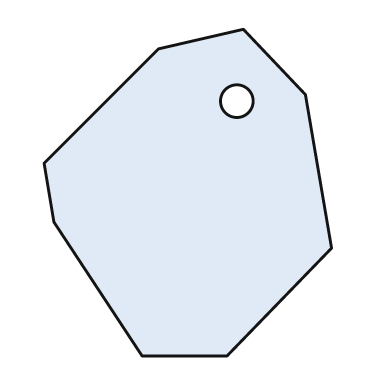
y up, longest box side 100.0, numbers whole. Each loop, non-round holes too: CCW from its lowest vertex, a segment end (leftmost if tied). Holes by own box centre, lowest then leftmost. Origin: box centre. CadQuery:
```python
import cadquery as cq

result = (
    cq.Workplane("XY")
    .moveTo(-14.0, -50.0)
    .lineTo(12.0, -50.0)
    .lineTo(44.0, -17.0)
    .lineTo(36.0, 30.0)
    .lineTo(17.0, 50.0)
    .lineTo(-9.0, 44.0)
    .lineTo(-44.0, 9.0)
    .lineTo(-41.0, -9.0)
    .close()
    .moveTo(15.0, 28.0)
    .circle(5.0)
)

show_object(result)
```